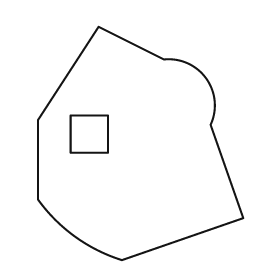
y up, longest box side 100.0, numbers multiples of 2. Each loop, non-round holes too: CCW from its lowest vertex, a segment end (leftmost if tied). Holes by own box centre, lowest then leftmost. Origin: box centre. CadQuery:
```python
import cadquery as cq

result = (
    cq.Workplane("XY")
    .moveTo(-8.0, -50.0)
    .lineTo(44.0, -32.0)
    .lineTo(30.0, 8.0)
    .threePointArc((28.0, 28.0), (10.0, 36.0))
    .lineTo(-18.0, 50.0)
    .lineTo(-44.0, 10.0)
    .lineTo(-44.0, -24.0)
    .threePointArc((-28.0, -40.0), (-8.0, -50.0))
    .close()
    .moveTo(-30.0, -4.0)
    .lineTo(-14.0, -4.0)
    .lineTo(-14.0, 12.0)
    .lineTo(-30.0, 12.0)
    .close()
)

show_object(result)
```